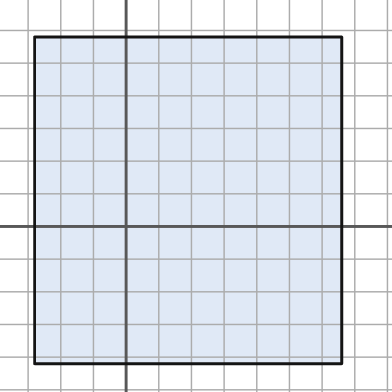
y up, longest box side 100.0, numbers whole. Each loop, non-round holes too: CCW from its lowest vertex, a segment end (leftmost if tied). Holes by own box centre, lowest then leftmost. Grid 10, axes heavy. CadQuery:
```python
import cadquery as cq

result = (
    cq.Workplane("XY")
    .moveTo(-28.0, -42.0)
    .lineTo(66.0, -42.0)
    .lineTo(66.0, 58.0)
    .lineTo(-28.0, 58.0)
    .close()
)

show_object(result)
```